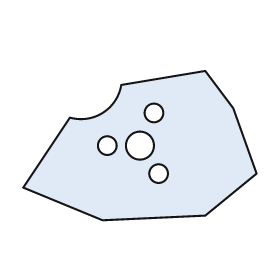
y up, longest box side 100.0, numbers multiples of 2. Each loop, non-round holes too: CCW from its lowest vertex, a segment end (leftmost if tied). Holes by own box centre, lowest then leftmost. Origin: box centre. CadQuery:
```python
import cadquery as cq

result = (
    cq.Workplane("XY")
    .moveTo(-16.0, -32.0)
    .lineTo(28.0, -30.0)
    .lineTo(50.0, -12.0)
    .lineTo(40.0, 16.0)
    .lineTo(28.0, 32.0)
    .lineTo(-8.0, 26.0)
    .threePointArc((-16.0, 14.0), (-30.0, 12.0))
    .lineTo(-50.0, -18.0)
    .close()
    .moveTo(8.0, -12.0)
    .circle(4.0)
    .moveTo(-14.0, 0.0)
    .circle(4.0)
    .moveTo(0.0, 0.0)
    .circle(6.0)
    .moveTo(6.0, 14.0)
    .circle(4.0)
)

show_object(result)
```